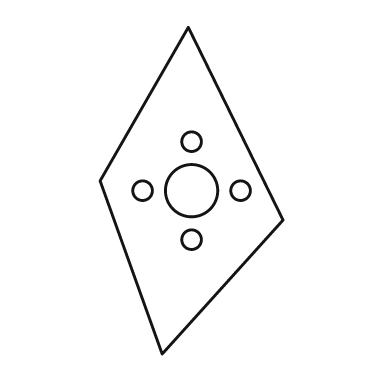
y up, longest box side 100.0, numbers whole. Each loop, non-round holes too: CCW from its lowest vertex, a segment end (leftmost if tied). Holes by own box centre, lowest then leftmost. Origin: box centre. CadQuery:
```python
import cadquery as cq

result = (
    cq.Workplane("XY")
    .moveTo(-9.0, -50.0)
    .lineTo(28.0, -9.0)
    .lineTo(-1.0, 50.0)
    .lineTo(-28.0, 3.0)
    .close()
    .moveTo(0.0, -15.0)
    .circle(3.0)
    .moveTo(-15.0, 0.0)
    .circle(3.0)
    .moveTo(0.0, 0.0)
    .circle(8.0)
    .moveTo(15.0, 0.0)
    .circle(3.0)
    .moveTo(0.0, 15.0)
    .circle(3.0)
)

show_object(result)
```